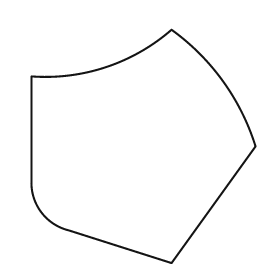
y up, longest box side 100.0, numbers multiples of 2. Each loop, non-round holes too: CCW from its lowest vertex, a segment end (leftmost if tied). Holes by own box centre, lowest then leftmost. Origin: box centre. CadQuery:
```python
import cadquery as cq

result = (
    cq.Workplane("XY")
    .moveTo(12.0, -50.0)
    .lineTo(48.0, 0.0)
    .threePointArc((34.0, 28.0), (12.0, 50.0))
    .threePointArc((-16.0, 34.0), (-48.0, 30.0))
    .lineTo(-48.0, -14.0)
    .threePointArc((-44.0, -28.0), (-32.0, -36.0))
    .close()
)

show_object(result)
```